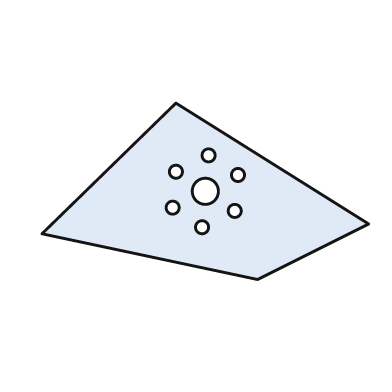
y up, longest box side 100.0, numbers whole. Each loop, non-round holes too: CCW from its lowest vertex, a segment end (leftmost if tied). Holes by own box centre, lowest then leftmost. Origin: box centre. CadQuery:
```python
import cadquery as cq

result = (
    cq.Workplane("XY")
    .moveTo(16.0, -27.0)
    .lineTo(50.0, -10.0)
    .lineTo(-9.0, 27.0)
    .lineTo(-50.0, -13.0)
    .close()
    .moveTo(-1.0, -11.0)
    .circle(2.0)
    .moveTo(9.0, -6.0)
    .circle(2.0)
    .moveTo(-10.0, -5.0)
    .circle(2.0)
    .moveTo(0.0, 0.0)
    .circle(4.0)
    .moveTo(10.0, 5.0)
    .circle(2.0)
    .moveTo(-9.0, 6.0)
    .circle(2.0)
    .moveTo(1.0, 11.0)
    .circle(2.0)
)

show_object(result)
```